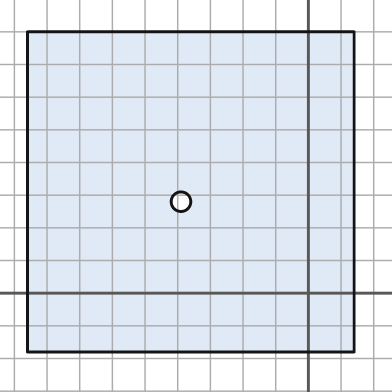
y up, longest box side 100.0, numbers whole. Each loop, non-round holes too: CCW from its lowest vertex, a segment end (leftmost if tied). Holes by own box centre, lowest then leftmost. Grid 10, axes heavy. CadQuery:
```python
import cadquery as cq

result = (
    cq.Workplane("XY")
    .moveTo(-86.0, -18.0)
    .lineTo(14.0, -18.0)
    .lineTo(14.0, 80.0)
    .lineTo(-86.0, 80.0)
    .close()
    .moveTo(-39.0, 28.0)
    .circle(3.0)
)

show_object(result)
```